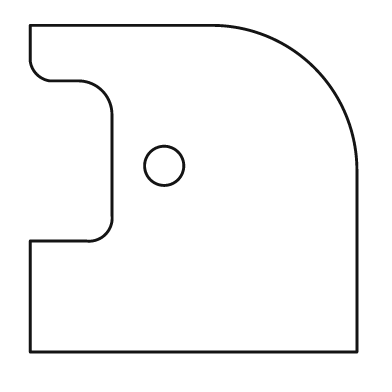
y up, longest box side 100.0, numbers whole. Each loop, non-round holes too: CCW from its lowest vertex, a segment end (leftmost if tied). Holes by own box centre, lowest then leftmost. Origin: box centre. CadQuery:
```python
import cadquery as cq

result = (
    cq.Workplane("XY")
    .moveTo(-50.0, -50.0)
    .lineTo(50.0, -50.0)
    .lineTo(50.0, 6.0)
    .threePointArc((37.0, 37.0), (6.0, 50.0))
    .lineTo(-50.0, 50.0)
    .lineTo(-50.0, 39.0)
    .threePointArc((-48.0, 35.0), (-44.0, 33.0))
    .lineTo(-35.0, 33.0)
    .threePointArc((-28.0, 30.0), (-25.0, 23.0))
    .lineTo(-25.0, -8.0)
    .threePointArc((-27.0, -14.0), (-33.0, -16.0))
    .lineTo(-50.0, -16.0)
    .close()
    .moveTo(-9.0, 7.0)
    .circle(6.0)
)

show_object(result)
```